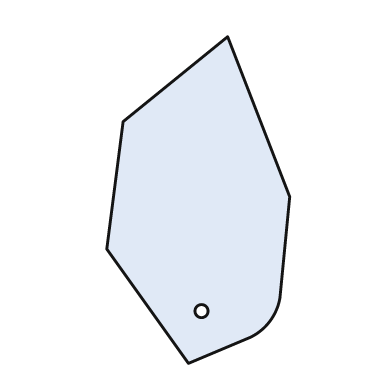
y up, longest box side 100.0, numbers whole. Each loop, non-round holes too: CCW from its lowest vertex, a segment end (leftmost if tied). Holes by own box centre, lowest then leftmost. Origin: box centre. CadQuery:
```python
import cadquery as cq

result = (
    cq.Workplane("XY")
    .moveTo(-3.0, -50.0)
    .lineTo(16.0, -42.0)
    .threePointArc((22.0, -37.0), (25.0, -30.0))
    .lineTo(28.0, 1.0)
    .lineTo(9.0, 50.0)
    .lineTo(-23.0, 24.0)
    .lineTo(-28.0, -15.0)
    .close()
    .moveTo(1.0, -34.0)
    .circle(2.0)
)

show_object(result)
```